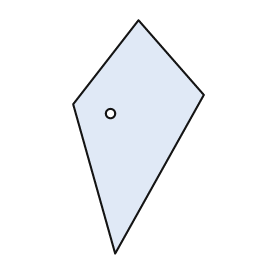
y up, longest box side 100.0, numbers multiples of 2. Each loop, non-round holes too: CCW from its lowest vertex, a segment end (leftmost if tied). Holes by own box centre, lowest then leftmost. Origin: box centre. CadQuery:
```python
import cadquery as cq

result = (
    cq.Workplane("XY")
    .moveTo(-10.0, -50.0)
    .lineTo(28.0, 18.0)
    .lineTo(0.0, 50.0)
    .lineTo(-28.0, 14.0)
    .close()
    .moveTo(-12.0, 10.0)
    .circle(2.0)
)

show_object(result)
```